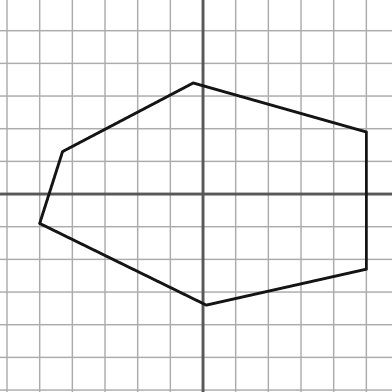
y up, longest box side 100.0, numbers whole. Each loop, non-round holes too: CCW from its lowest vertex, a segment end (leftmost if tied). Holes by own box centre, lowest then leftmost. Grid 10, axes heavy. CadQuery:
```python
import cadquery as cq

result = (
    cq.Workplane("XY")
    .moveTo(1.0, -34.0)
    .lineTo(50.0, -23.0)
    .lineTo(50.0, 19.0)
    .lineTo(-3.0, 34.0)
    .lineTo(-43.0, 13.0)
    .lineTo(-50.0, -9.0)
    .close()
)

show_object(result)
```